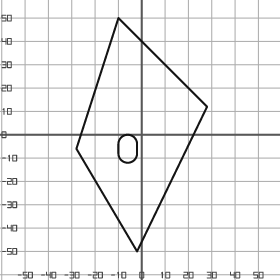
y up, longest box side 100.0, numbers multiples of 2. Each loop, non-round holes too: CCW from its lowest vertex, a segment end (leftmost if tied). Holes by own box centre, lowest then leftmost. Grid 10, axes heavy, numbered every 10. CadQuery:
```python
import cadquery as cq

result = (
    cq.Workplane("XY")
    .moveTo(-2.0, -50.0)
    .lineTo(28.0, 12.0)
    .lineTo(-10.0, 50.0)
    .lineTo(-28.0, -6.0)
    .close()
    .moveTo(-10.0, -8.0)
    .threePointArc((-6.0, -12.0), (-2.0, -8.0))
    .lineTo(-2.0, -4.0)
    .threePointArc((-6.0, 0.0), (-10.0, -4.0))
    .close()
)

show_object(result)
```